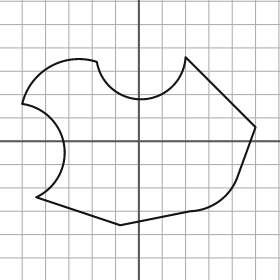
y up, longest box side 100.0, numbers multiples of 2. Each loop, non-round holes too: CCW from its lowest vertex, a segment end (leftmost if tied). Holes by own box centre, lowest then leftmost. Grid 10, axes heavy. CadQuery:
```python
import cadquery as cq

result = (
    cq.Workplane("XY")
    .moveTo(-8.0, -36.0)
    .lineTo(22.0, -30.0)
    .threePointArc((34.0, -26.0), (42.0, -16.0))
    .lineTo(50.0, 6.0)
    .lineTo(20.0, 36.0)
    .threePointArc((2.0, 18.0), (-18.0, 34.0))
    .threePointArc((-38.0, 32.0), (-50.0, 16.0))
    .threePointArc((-32.0, -2.0), (-44.0, -24.0))
    .close()
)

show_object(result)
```